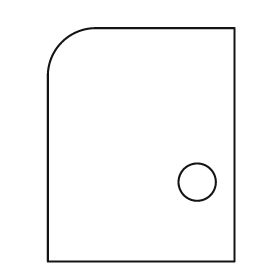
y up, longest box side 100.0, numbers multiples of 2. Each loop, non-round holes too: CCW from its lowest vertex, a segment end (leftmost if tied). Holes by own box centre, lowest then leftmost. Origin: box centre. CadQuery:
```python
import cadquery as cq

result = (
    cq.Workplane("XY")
    .moveTo(-40.0, -50.0)
    .lineTo(40.0, -50.0)
    .lineTo(40.0, 50.0)
    .lineTo(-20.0, 50.0)
    .threePointArc((-34.0, 44.0), (-40.0, 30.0))
    .close()
    .moveTo(24.0, -16.0)
    .circle(8.0)
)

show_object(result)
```